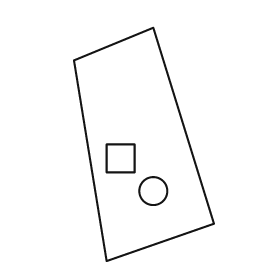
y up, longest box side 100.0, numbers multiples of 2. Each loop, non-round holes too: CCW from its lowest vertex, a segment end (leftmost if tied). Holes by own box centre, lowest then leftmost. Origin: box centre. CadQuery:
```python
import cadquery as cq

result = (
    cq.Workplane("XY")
    .moveTo(-16.0, -50.0)
    .lineTo(30.0, -34.0)
    .lineTo(4.0, 50.0)
    .lineTo(-30.0, 36.0)
    .close()
    .moveTo(4.0, -20.0)
    .circle(6.0)
    .moveTo(-16.0, -12.0)
    .lineTo(-4.0, -12.0)
    .lineTo(-4.0, 0.0)
    .lineTo(-16.0, 0.0)
    .close()
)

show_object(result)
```